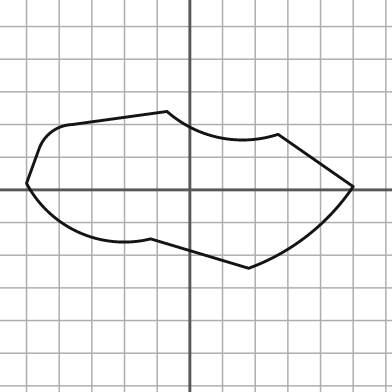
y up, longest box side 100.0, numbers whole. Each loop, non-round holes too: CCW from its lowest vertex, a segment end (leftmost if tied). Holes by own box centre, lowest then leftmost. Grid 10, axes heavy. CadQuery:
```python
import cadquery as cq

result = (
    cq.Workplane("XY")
    .moveTo(18.0, -24.0)
    .threePointArc((36.0, -14.0), (50.0, 1.0))
    .lineTo(27.0, 17.0)
    .threePointArc((9.0, 16.0), (-7.0, 24.0))
    .lineTo(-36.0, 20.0)
    .threePointArc((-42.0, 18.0), (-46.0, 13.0))
    .lineTo(-50.0, 2.0)
    .threePointArc((-34.0, -13.0), (-12.0, -15.0))
    .close()
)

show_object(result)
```